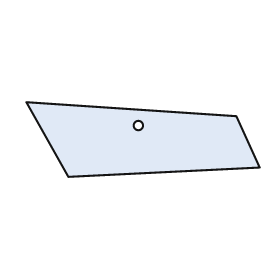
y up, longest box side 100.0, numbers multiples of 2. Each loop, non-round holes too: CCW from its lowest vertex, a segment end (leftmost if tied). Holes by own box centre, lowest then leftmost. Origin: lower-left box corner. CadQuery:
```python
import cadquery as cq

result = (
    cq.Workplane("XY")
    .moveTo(18.0, 0.0)
    .lineTo(100.0, 4.0)
    .lineTo(90.0, 26.0)
    .lineTo(0.0, 32.0)
    .close()
    .moveTo(48.0, 22.0)
    .circle(2.0)
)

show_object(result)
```